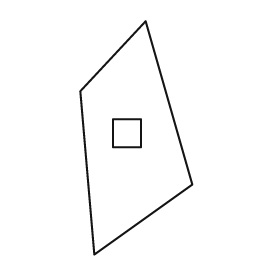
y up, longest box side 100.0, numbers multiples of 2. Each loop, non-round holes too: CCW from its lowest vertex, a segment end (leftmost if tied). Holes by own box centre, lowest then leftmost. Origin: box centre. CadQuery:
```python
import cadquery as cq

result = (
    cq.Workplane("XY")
    .moveTo(-18.0, -50.0)
    .lineTo(24.0, -20.0)
    .lineTo(4.0, 50.0)
    .lineTo(-24.0, 20.0)
    .close()
    .moveTo(-10.0, -4.0)
    .lineTo(2.0, -4.0)
    .lineTo(2.0, 8.0)
    .lineTo(-10.0, 8.0)
    .close()
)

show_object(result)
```